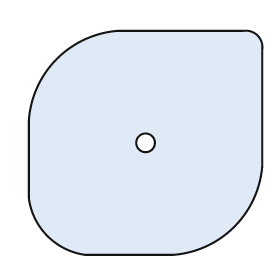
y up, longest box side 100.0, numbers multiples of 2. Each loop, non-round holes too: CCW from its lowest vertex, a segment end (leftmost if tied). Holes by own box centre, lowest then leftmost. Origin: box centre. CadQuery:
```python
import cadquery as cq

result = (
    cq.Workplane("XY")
    .moveTo(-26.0, -48.0)
    .lineTo(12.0, -48.0)
    .threePointArc((38.0, -36.0), (50.0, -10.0))
    .lineTo(50.0, 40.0)
    .threePointArc((48.0, 46.0), (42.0, 48.0))
    .lineTo(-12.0, 48.0)
    .threePointArc((-38.0, 36.0), (-50.0, 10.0))
    .lineTo(-50.0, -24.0)
    .threePointArc((-42.0, -40.0), (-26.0, -48.0))
    .close()
    .moveTo(0.0, 0.0)
    .circle(4.0)
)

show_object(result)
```